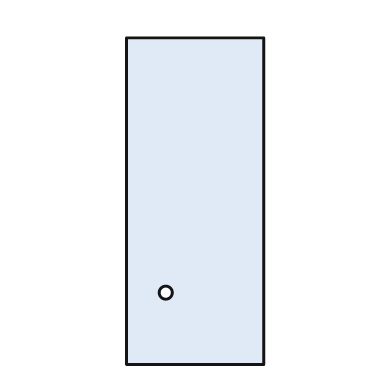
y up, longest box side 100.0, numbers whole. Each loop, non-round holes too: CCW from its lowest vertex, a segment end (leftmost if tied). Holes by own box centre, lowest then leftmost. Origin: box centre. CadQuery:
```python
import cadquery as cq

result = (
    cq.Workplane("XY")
    .moveTo(-21.0, -50.0)
    .lineTo(21.0, -50.0)
    .lineTo(21.0, 50.0)
    .lineTo(-21.0, 50.0)
    .close()
    .moveTo(-9.0, -28.0)
    .circle(2.0)
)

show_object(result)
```